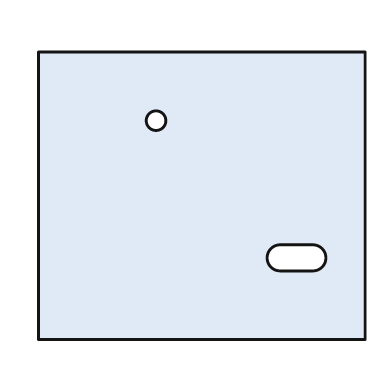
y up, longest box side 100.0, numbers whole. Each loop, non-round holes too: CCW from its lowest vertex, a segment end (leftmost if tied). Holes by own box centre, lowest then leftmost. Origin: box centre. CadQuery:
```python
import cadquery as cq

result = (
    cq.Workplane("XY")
    .moveTo(-50.0, -44.0)
    .lineTo(50.0, -44.0)
    .lineTo(50.0, 44.0)
    .lineTo(-50.0, 44.0)
    .close()
    .moveTo(24.0, -23.0)
    .lineTo(34.0, -23.0)
    .threePointArc((38.0, -19.0), (34.0, -15.0))
    .lineTo(24.0, -15.0)
    .threePointArc((20.0, -19.0), (24.0, -23.0))
    .close()
    .moveTo(-14.0, 23.0)
    .circle(3.0)
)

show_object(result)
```